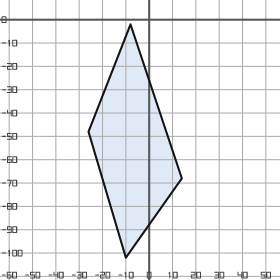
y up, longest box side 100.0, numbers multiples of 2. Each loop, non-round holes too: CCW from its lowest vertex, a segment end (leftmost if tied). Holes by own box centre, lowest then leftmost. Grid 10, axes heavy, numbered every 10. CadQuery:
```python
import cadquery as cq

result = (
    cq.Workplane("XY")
    .moveTo(-10.0, -102.0)
    .lineTo(14.0, -68.0)
    .lineTo(-8.0, -2.0)
    .lineTo(-26.0, -48.0)
    .close()
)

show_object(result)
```